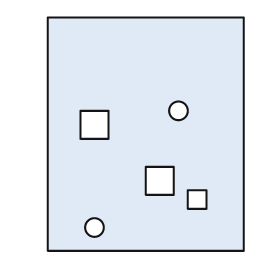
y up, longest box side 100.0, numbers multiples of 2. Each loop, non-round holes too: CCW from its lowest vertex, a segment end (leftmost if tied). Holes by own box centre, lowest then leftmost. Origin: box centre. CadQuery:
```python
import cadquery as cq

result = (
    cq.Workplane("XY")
    .moveTo(-42.0, -50.0)
    .lineTo(42.0, -50.0)
    .lineTo(42.0, 50.0)
    .lineTo(-42.0, 50.0)
    .close()
    .moveTo(-22.0, -40.0)
    .circle(4.0)
    .moveTo(18.0, -32.0)
    .lineTo(26.0, -32.0)
    .lineTo(26.0, -24.0)
    .lineTo(18.0, -24.0)
    .close()
    .moveTo(0.0, -26.0)
    .lineTo(12.0, -26.0)
    .lineTo(12.0, -14.0)
    .lineTo(0.0, -14.0)
    .close()
    .moveTo(-28.0, -2.0)
    .lineTo(-16.0, -2.0)
    .lineTo(-16.0, 10.0)
    .lineTo(-28.0, 10.0)
    .close()
    .moveTo(14.0, 10.0)
    .circle(4.0)
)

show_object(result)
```